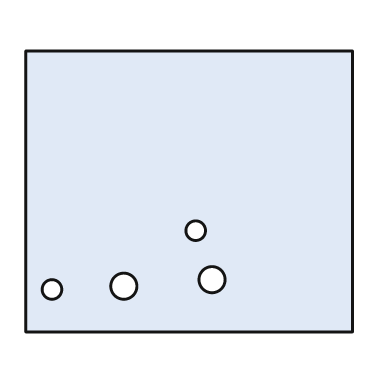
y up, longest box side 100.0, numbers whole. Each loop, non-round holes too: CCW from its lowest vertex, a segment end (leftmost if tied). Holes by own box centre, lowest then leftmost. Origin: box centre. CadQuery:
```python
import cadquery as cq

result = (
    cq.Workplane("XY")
    .moveTo(-50.0, -43.0)
    .lineTo(50.0, -43.0)
    .lineTo(50.0, 43.0)
    .lineTo(-50.0, 43.0)
    .close()
    .moveTo(-42.0, -30.0)
    .circle(3.0)
    .moveTo(-20.0, -29.0)
    .circle(4.0)
    .moveTo(7.0, -27.0)
    .circle(4.0)
    .moveTo(2.0, -12.0)
    .circle(3.0)
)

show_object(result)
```